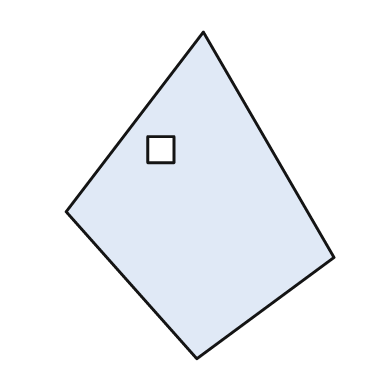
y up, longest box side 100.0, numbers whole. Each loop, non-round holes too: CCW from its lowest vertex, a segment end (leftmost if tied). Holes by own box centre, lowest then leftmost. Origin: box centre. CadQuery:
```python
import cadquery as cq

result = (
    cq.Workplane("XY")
    .moveTo(-1.0, -50.0)
    .lineTo(41.0, -19.0)
    .lineTo(1.0, 50.0)
    .lineTo(-41.0, -5.0)
    .close()
    .moveTo(-16.0, 10.0)
    .lineTo(-8.0, 10.0)
    .lineTo(-8.0, 18.0)
    .lineTo(-16.0, 18.0)
    .close()
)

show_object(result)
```